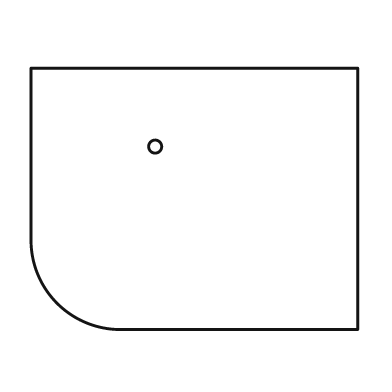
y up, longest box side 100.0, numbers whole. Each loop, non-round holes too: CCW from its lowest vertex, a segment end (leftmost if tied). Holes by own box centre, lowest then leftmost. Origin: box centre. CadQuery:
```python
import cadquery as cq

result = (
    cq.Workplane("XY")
    .moveTo(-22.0, -40.0)
    .lineTo(50.0, -40.0)
    .lineTo(50.0, 40.0)
    .lineTo(-50.0, 40.0)
    .lineTo(-50.0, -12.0)
    .threePointArc((-42.0, -32.0), (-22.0, -40.0))
    .close()
    .moveTo(-12.0, 16.0)
    .circle(2.0)
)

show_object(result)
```